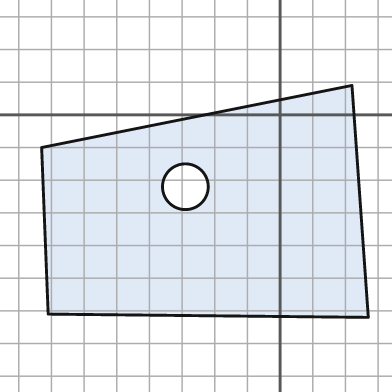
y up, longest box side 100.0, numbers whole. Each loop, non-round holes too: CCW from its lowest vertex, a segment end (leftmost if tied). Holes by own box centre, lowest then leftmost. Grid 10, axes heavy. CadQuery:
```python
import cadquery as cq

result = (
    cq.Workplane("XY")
    .moveTo(27.0, -62.0)
    .lineTo(22.0, 9.0)
    .lineTo(-73.0, -10.0)
    .lineTo(-71.0, -61.0)
    .close()
    .moveTo(-29.0, -22.0)
    .circle(7.0)
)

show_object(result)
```